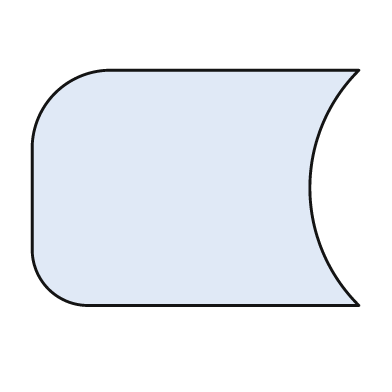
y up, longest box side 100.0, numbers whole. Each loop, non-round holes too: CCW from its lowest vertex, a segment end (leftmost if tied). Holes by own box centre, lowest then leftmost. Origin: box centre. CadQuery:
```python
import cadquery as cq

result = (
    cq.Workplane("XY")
    .moveTo(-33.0, -36.0)
    .lineTo(50.0, -36.0)
    .threePointArc((35.0, 0.0), (50.0, 36.0))
    .lineTo(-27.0, 36.0)
    .threePointArc((-43.0, 29.0), (-50.0, 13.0))
    .lineTo(-50.0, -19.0)
    .threePointArc((-45.0, -31.0), (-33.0, -36.0))
    .close()
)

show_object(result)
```